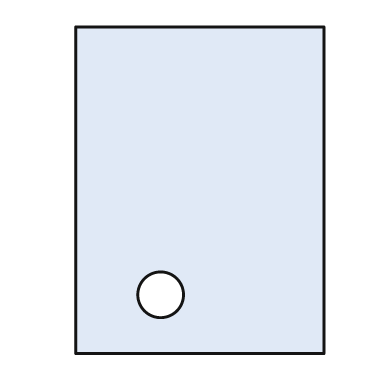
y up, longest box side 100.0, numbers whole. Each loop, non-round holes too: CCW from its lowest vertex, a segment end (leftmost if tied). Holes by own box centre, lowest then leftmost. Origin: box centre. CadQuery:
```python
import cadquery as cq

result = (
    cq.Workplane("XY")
    .moveTo(-38.0, -50.0)
    .lineTo(38.0, -50.0)
    .lineTo(38.0, 50.0)
    .lineTo(-38.0, 50.0)
    .close()
    .moveTo(-12.0, -32.0)
    .circle(7.0)
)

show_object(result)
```